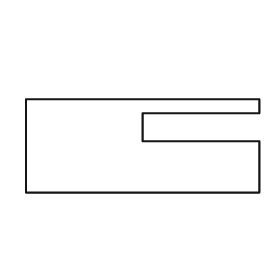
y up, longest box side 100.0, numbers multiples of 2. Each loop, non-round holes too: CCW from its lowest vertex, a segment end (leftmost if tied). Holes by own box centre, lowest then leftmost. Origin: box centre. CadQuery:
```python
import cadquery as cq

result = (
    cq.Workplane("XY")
    .moveTo(-50.0, -20.0)
    .lineTo(50.0, -20.0)
    .lineTo(50.0, 2.0)
    .lineTo(0.0, 2.0)
    .lineTo(0.0, 14.0)
    .lineTo(50.0, 14.0)
    .lineTo(50.0, 20.0)
    .lineTo(-50.0, 20.0)
    .close()
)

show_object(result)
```